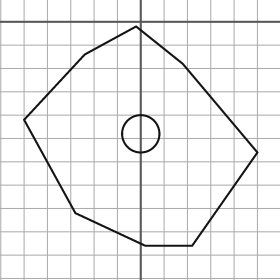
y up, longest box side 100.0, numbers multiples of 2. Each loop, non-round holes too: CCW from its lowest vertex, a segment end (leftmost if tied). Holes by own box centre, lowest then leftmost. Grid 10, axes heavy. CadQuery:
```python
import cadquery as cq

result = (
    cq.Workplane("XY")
    .moveTo(2.0, -96.0)
    .lineTo(22.0, -96.0)
    .lineTo(50.0, -56.0)
    .lineTo(18.0, -18.0)
    .lineTo(-2.0, -2.0)
    .lineTo(-24.0, -14.0)
    .lineTo(-50.0, -42.0)
    .lineTo(-28.0, -82.0)
    .close()
    .moveTo(0.0, -48.0)
    .circle(8.0)
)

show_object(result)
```